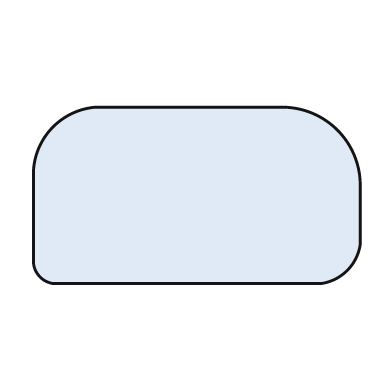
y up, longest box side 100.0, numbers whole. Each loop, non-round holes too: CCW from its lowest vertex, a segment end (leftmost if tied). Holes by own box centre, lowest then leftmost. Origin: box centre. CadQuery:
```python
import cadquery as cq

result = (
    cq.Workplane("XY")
    .moveTo(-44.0, -27.0)
    .lineTo(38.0, -27.0)
    .threePointArc((46.0, -23.0), (50.0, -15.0))
    .lineTo(50.0, 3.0)
    .threePointArc((43.0, 20.0), (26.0, 27.0))
    .lineTo(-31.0, 27.0)
    .threePointArc((-44.0, 21.0), (-50.0, 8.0))
    .lineTo(-50.0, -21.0)
    .threePointArc((-48.0, -25.0), (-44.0, -27.0))
    .close()
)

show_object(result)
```